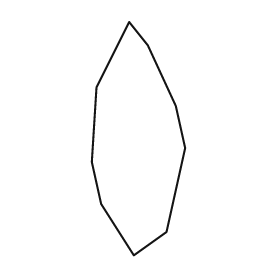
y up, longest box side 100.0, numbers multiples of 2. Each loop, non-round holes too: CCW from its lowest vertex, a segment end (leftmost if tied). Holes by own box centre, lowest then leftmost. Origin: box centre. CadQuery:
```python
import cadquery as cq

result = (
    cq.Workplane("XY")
    .moveTo(-2.0, -50.0)
    .lineTo(12.0, -40.0)
    .lineTo(20.0, -4.0)
    .lineTo(16.0, 14.0)
    .lineTo(4.0, 40.0)
    .lineTo(-4.0, 50.0)
    .lineTo(-18.0, 22.0)
    .lineTo(-20.0, -10.0)
    .lineTo(-16.0, -28.0)
    .close()
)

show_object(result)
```